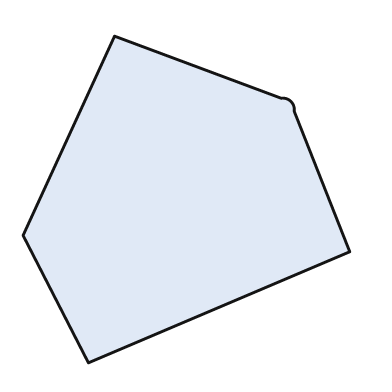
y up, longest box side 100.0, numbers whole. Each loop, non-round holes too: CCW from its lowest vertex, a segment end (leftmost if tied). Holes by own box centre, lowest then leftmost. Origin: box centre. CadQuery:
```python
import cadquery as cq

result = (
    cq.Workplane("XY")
    .moveTo(-30.0, -50.0)
    .lineTo(50.0, -16.0)
    .lineTo(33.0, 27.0)
    .threePointArc((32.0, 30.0), (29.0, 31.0))
    .lineTo(-22.0, 50.0)
    .lineTo(-50.0, -11.0)
    .close()
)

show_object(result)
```